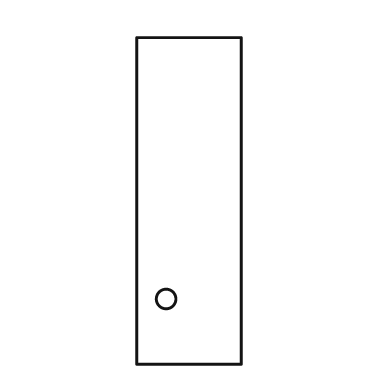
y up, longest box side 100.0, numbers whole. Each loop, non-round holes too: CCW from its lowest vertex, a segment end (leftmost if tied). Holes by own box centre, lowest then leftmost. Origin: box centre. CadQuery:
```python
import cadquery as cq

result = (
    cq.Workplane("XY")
    .moveTo(-16.0, -50.0)
    .lineTo(16.0, -50.0)
    .lineTo(16.0, 50.0)
    .lineTo(-16.0, 50.0)
    .close()
    .moveTo(-7.0, -30.0)
    .circle(3.0)
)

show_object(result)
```